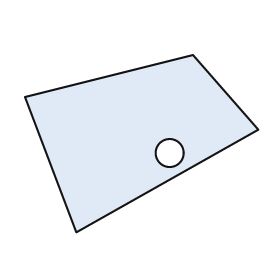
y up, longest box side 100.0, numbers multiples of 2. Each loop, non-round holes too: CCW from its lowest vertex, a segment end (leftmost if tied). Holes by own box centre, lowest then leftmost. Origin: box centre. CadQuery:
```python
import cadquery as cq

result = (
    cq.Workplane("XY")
    .moveTo(-28.0, -38.0)
    .lineTo(50.0, 6.0)
    .lineTo(22.0, 38.0)
    .lineTo(-50.0, 20.0)
    .close()
    .moveTo(12.0, -4.0)
    .circle(6.0)
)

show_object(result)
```